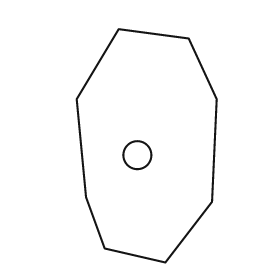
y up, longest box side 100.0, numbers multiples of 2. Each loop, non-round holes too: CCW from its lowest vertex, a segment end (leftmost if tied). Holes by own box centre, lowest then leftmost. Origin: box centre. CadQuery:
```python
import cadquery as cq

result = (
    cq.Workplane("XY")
    .moveTo(8.0, -50.0)
    .lineTo(28.0, -24.0)
    .lineTo(30.0, 20.0)
    .lineTo(18.0, 46.0)
    .lineTo(-12.0, 50.0)
    .lineTo(-30.0, 20.0)
    .lineTo(-26.0, -22.0)
    .lineTo(-18.0, -44.0)
    .close()
    .moveTo(-4.0, -4.0)
    .circle(6.0)
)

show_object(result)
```